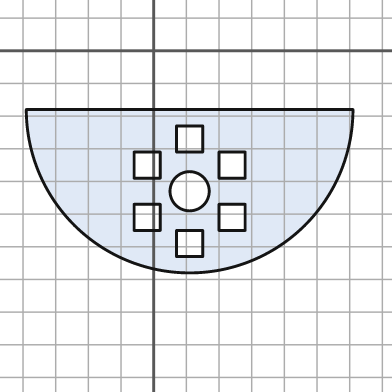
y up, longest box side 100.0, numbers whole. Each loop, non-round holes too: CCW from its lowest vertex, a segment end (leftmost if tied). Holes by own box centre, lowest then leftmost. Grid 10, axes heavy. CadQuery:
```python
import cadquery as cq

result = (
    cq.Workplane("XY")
    .moveTo(-39.0, -18.0)
    .threePointArc((11.0, -68.0), (61.0, -18.0))
    .close()
    .moveTo(7.0, -63.0)
    .lineTo(15.0, -63.0)
    .lineTo(15.0, -55.0)
    .lineTo(7.0, -55.0)
    .close()
    .moveTo(-6.0, -55.0)
    .lineTo(2.0, -55.0)
    .lineTo(2.0, -47.0)
    .lineTo(-6.0, -47.0)
    .close()
    .moveTo(20.0, -55.0)
    .lineTo(28.0, -55.0)
    .lineTo(28.0, -47.0)
    .lineTo(20.0, -47.0)
    .close()
    .moveTo(11.0, -43.0)
    .circle(6.0)
    .moveTo(-6.0, -39.0)
    .lineTo(2.0, -39.0)
    .lineTo(2.0, -31.0)
    .lineTo(-6.0, -31.0)
    .close()
    .moveTo(20.0, -39.0)
    .lineTo(28.0, -39.0)
    .lineTo(28.0, -31.0)
    .lineTo(20.0, -31.0)
    .close()
    .moveTo(7.0, -31.0)
    .lineTo(15.0, -31.0)
    .lineTo(15.0, -23.0)
    .lineTo(7.0, -23.0)
    .close()
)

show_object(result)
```